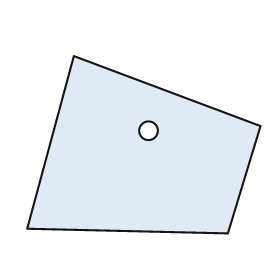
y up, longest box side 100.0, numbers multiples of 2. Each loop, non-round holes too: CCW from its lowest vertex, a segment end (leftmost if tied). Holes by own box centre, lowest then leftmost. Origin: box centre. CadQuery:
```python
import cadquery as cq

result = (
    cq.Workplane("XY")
    .moveTo(36.0, -38.0)
    .lineTo(50.0, 8.0)
    .lineTo(-30.0, 38.0)
    .lineTo(-50.0, -36.0)
    .close()
    .moveTo(2.0, 6.0)
    .circle(4.0)
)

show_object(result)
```